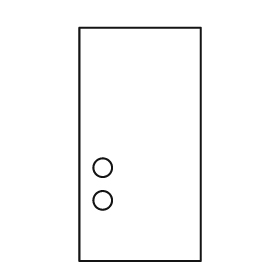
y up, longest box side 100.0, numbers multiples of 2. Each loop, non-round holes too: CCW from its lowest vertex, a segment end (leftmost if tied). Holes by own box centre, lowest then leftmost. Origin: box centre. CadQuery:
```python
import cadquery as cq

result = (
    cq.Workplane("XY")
    .moveTo(-26.0, -50.0)
    .lineTo(26.0, -50.0)
    .lineTo(26.0, 50.0)
    .lineTo(-26.0, 50.0)
    .close()
    .moveTo(-16.0, -24.0)
    .circle(4.0)
    .moveTo(-16.0, -10.0)
    .circle(4.0)
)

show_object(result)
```